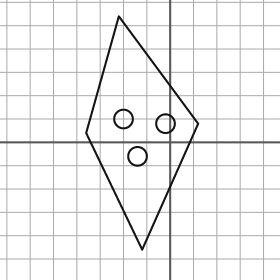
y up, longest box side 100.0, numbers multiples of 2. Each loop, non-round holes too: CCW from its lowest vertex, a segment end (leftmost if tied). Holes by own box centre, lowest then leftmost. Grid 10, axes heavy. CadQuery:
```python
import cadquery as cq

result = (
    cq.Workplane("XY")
    .moveTo(-12.0, -46.0)
    .lineTo(12.0, 8.0)
    .lineTo(-22.0, 54.0)
    .lineTo(-36.0, 4.0)
    .close()
    .moveTo(-14.0, -6.0)
    .circle(4.0)
    .moveTo(-2.0, 8.0)
    .circle(4.0)
    .moveTo(-20.0, 10.0)
    .circle(4.0)
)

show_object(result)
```